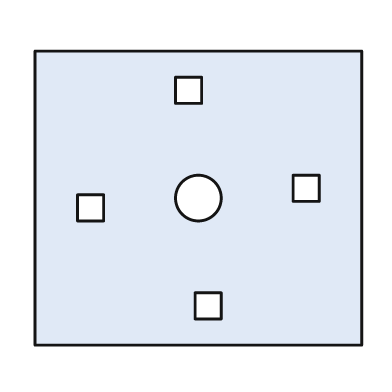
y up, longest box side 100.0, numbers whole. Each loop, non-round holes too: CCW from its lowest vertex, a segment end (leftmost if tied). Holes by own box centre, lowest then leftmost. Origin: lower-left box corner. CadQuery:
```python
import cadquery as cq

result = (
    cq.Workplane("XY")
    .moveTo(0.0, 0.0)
    .lineTo(100.0, 0.0)
    .lineTo(100.0, 90.0)
    .lineTo(0.0, 90.0)
    .close()
    .moveTo(49.0, 8.0)
    .lineTo(57.0, 8.0)
    .lineTo(57.0, 16.0)
    .lineTo(49.0, 16.0)
    .close()
    .moveTo(13.0, 38.0)
    .lineTo(21.0, 38.0)
    .lineTo(21.0, 46.0)
    .lineTo(13.0, 46.0)
    .close()
    .moveTo(50.0, 45.0)
    .circle(7.0)
    .moveTo(79.0, 44.0)
    .lineTo(87.0, 44.0)
    .lineTo(87.0, 52.0)
    .lineTo(79.0, 52.0)
    .close()
    .moveTo(43.0, 74.0)
    .lineTo(51.0, 74.0)
    .lineTo(51.0, 82.0)
    .lineTo(43.0, 82.0)
    .close()
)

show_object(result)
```